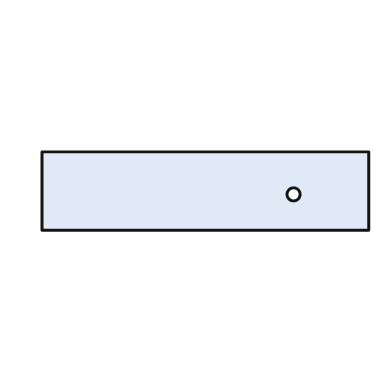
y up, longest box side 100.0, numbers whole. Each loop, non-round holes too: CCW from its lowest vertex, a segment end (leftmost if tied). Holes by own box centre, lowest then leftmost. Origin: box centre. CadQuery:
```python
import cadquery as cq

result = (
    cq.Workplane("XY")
    .moveTo(-50.0, -12.0)
    .lineTo(50.0, -12.0)
    .lineTo(50.0, 12.0)
    .lineTo(-50.0, 12.0)
    .close()
    .moveTo(27.0, -1.0)
    .circle(2.0)
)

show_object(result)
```